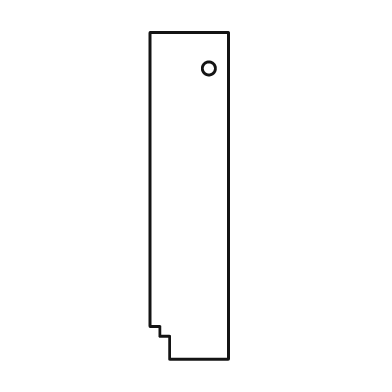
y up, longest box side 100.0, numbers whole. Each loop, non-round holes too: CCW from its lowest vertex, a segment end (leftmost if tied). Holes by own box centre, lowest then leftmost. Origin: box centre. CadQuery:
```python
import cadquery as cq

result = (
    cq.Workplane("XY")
    .moveTo(-6.0, -50.0)
    .lineTo(12.0, -50.0)
    .lineTo(12.0, 50.0)
    .lineTo(-12.0, 50.0)
    .lineTo(-12.0, -40.0)
    .lineTo(-9.0, -40.0)
    .lineTo(-9.0, -43.0)
    .lineTo(-6.0, -43.0)
    .close()
    .moveTo(6.0, 39.0)
    .circle(2.0)
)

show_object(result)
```